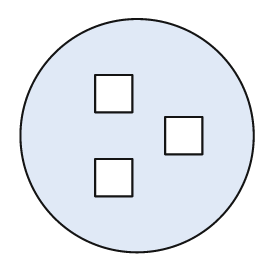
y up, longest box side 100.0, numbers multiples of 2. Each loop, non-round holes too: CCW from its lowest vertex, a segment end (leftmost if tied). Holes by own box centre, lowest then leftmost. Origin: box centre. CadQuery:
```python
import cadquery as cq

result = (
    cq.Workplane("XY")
    .moveTo(0.0, 0.0)
    .circle(50.0)
    .moveTo(-18.0, -26.0)
    .lineTo(-2.0, -26.0)
    .lineTo(-2.0, -10.0)
    .lineTo(-18.0, -10.0)
    .close()
    .moveTo(12.0, -8.0)
    .lineTo(28.0, -8.0)
    .lineTo(28.0, 8.0)
    .lineTo(12.0, 8.0)
    .close()
    .moveTo(-18.0, 10.0)
    .lineTo(-2.0, 10.0)
    .lineTo(-2.0, 26.0)
    .lineTo(-18.0, 26.0)
    .close()
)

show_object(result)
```